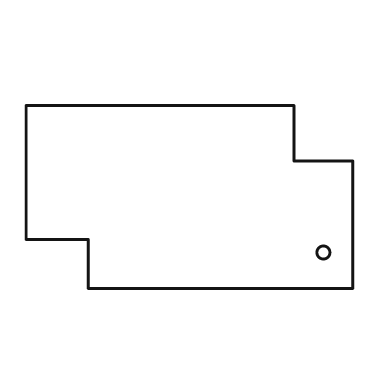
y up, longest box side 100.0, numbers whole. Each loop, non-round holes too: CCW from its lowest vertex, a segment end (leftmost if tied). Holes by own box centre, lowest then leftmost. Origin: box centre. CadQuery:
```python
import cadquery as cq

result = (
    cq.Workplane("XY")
    .moveTo(-31.0, -28.0)
    .lineTo(50.0, -28.0)
    .lineTo(50.0, 11.0)
    .lineTo(32.0, 11.0)
    .lineTo(32.0, 28.0)
    .lineTo(-50.0, 28.0)
    .lineTo(-50.0, -13.0)
    .lineTo(-31.0, -13.0)
    .close()
    .moveTo(41.0, -17.0)
    .circle(2.0)
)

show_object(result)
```